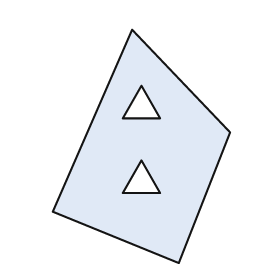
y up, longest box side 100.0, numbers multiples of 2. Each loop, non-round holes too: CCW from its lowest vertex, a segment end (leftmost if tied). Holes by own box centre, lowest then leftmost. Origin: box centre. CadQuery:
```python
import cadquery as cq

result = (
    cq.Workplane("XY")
    .moveTo(16.0, -50.0)
    .lineTo(38.0, 6.0)
    .lineTo(-4.0, 50.0)
    .lineTo(-38.0, -28.0)
    .close()
    .moveTo(-8.0, -20.0)
    .lineTo(8.0, -20.0)
    .lineTo(0.0, -6.0)
    .close()
    .moveTo(-8.0, 12.0)
    .lineTo(8.0, 12.0)
    .lineTo(0.0, 26.0)
    .close()
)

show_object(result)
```